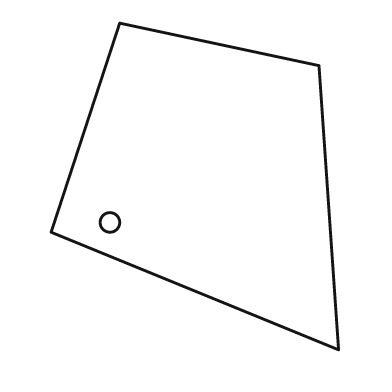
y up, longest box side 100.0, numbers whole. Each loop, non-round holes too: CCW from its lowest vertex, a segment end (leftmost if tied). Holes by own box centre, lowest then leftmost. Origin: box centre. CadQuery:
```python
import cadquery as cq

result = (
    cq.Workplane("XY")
    .moveTo(44.0, -50.0)
    .lineTo(38.0, 37.0)
    .lineTo(-23.0, 50.0)
    .lineTo(-44.0, -14.0)
    .close()
    .moveTo(-26.0, -11.0)
    .circle(3.0)
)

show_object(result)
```